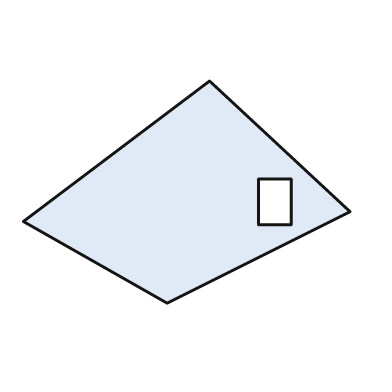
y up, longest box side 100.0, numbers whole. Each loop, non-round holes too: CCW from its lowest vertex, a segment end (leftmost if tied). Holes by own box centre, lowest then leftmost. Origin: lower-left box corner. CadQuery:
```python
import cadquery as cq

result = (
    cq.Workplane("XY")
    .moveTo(44.0, 0.0)
    .lineTo(100.0, 28.0)
    .lineTo(57.0, 68.0)
    .lineTo(0.0, 25.0)
    .close()
    .moveTo(72.0, 24.0)
    .lineTo(82.0, 24.0)
    .lineTo(82.0, 38.0)
    .lineTo(72.0, 38.0)
    .close()
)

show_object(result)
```